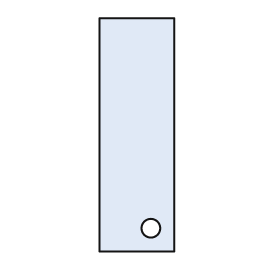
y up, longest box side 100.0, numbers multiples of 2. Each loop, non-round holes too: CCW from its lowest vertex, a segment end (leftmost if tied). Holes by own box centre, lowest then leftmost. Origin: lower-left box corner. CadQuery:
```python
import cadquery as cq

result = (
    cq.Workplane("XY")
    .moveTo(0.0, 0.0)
    .lineTo(32.0, 0.0)
    .lineTo(32.0, 100.0)
    .lineTo(0.0, 100.0)
    .close()
    .moveTo(22.0, 10.0)
    .circle(4.0)
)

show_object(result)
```